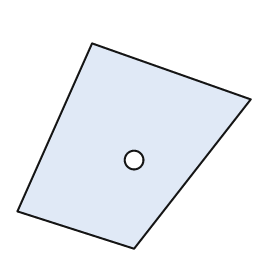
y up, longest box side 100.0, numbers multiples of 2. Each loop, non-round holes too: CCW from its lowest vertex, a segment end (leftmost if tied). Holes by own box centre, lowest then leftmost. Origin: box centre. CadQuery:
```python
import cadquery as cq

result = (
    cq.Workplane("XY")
    .moveTo(0.0, -44.0)
    .lineTo(50.0, 20.0)
    .lineTo(-18.0, 44.0)
    .lineTo(-50.0, -28.0)
    .close()
    .moveTo(0.0, -6.0)
    .circle(4.0)
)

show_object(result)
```